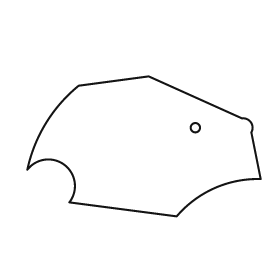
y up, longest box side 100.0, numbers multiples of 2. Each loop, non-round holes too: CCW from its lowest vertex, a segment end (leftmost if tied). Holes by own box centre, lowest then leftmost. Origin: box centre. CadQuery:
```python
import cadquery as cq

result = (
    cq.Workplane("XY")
    .moveTo(14.0, -30.0)
    .threePointArc((30.0, -18.0), (50.0, -14.0))
    .lineTo(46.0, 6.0)
    .threePointArc((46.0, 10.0), (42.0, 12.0))
    .lineTo(2.0, 30.0)
    .lineTo(-28.0, 26.0)
    .threePointArc((-42.0, 10.0), (-50.0, -10.0))
    .threePointArc((-34.0, -8.0), (-32.0, -24.0))
    .close()
    .moveTo(22.0, 8.0)
    .circle(2.0)
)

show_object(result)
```